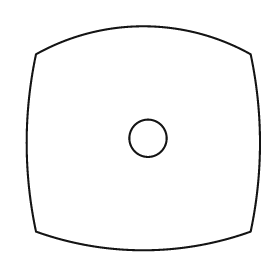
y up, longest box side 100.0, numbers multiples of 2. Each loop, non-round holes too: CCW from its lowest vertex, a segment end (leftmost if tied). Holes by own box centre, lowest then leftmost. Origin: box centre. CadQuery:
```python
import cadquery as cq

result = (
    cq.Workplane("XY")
    .moveTo(-46.0, -40.0)
    .threePointArc((0.0, -48.0), (46.0, -40.0))
    .threePointArc((50.0, -2.0), (46.0, 36.0))
    .threePointArc((0.0, 48.0), (-46.0, 36.0))
    .threePointArc((-50.0, -2.0), (-46.0, -40.0))
    .close()
    .moveTo(2.0, 0.0)
    .circle(8.0)
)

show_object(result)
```